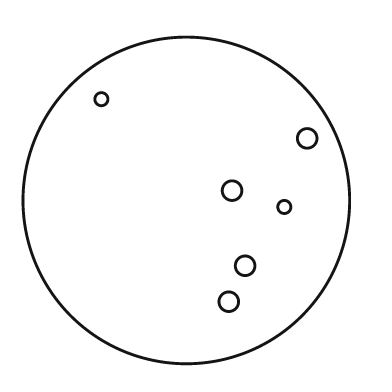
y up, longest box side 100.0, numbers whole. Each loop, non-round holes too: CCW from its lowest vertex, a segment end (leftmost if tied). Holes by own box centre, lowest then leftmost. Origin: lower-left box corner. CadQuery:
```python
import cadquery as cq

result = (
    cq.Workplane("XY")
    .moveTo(50.0, 50.0)
    .circle(50.0)
    .moveTo(63.0, 19.0)
    .circle(3.0)
    .moveTo(68.0, 30.0)
    .circle(3.0)
    .moveTo(80.0, 48.0)
    .circle(2.0)
    .moveTo(64.0, 53.0)
    .circle(3.0)
    .moveTo(87.0, 69.0)
    .circle(3.0)
    .moveTo(24.0, 81.0)
    .circle(2.0)
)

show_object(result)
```